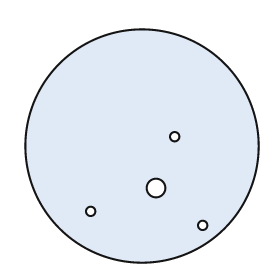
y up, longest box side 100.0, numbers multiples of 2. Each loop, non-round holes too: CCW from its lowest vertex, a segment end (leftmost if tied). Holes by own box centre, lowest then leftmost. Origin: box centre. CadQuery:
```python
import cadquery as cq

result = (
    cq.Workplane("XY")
    .moveTo(0.0, 0.0)
    .circle(50.0)
    .moveTo(26.0, -34.0)
    .circle(2.0)
    .moveTo(-22.0, -28.0)
    .circle(2.0)
    .moveTo(6.0, -18.0)
    .circle(4.0)
    .moveTo(14.0, 4.0)
    .circle(2.0)
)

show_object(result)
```